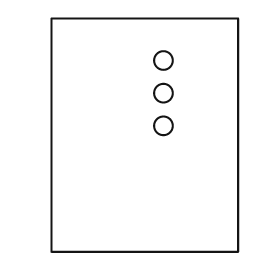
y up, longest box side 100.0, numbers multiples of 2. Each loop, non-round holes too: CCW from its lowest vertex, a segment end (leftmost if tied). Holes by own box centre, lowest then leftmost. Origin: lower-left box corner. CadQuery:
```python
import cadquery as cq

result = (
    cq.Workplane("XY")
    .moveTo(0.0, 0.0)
    .lineTo(80.0, 0.0)
    .lineTo(80.0, 100.0)
    .lineTo(0.0, 100.0)
    .close()
    .moveTo(48.0, 54.0)
    .circle(4.0)
    .moveTo(48.0, 68.0)
    .circle(4.0)
    .moveTo(48.0, 82.0)
    .circle(4.0)
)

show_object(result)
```